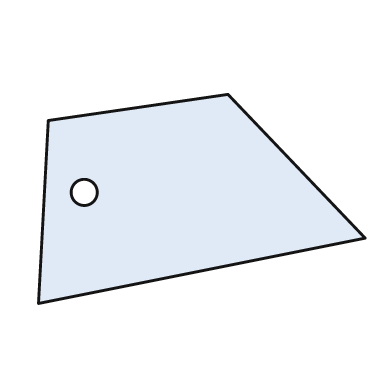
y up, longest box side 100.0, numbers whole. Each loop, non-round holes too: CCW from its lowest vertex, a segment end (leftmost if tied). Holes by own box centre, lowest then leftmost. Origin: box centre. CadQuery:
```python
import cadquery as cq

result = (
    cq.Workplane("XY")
    .moveTo(-50.0, -32.0)
    .lineTo(50.0, -12.0)
    .lineTo(8.0, 32.0)
    .lineTo(-47.0, 24.0)
    .close()
    .moveTo(-36.0, 2.0)
    .circle(4.0)
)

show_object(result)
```